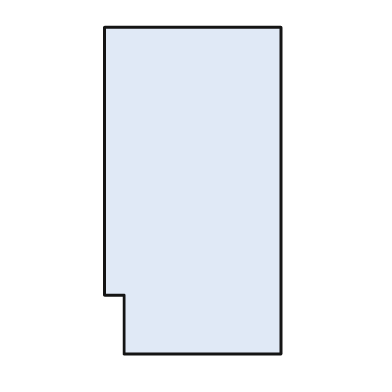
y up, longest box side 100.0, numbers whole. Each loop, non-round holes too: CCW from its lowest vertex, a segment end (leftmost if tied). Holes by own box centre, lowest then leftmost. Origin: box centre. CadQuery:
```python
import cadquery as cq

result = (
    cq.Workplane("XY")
    .moveTo(-21.0, -50.0)
    .lineTo(27.0, -50.0)
    .lineTo(27.0, 50.0)
    .lineTo(-27.0, 50.0)
    .lineTo(-27.0, -32.0)
    .lineTo(-21.0, -32.0)
    .close()
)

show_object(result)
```